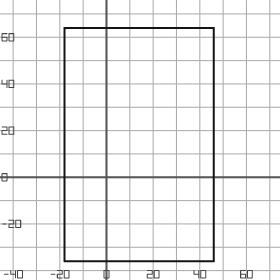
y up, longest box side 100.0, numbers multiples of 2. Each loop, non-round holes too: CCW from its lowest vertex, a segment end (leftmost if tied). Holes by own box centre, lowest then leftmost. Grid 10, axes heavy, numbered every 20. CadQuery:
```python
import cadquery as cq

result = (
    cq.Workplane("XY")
    .moveTo(-18.0, -36.0)
    .lineTo(46.0, -36.0)
    .lineTo(46.0, 64.0)
    .lineTo(-18.0, 64.0)
    .close()
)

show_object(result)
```